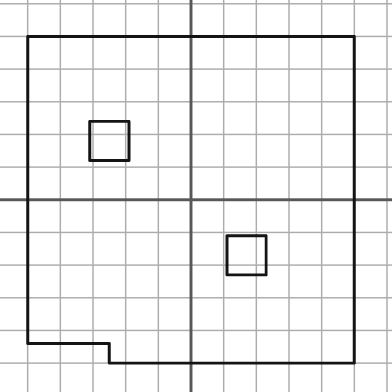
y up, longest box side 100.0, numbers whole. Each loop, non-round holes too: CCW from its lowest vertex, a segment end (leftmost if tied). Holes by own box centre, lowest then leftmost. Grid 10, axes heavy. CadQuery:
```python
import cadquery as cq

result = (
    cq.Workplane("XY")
    .moveTo(-25.0, -50.0)
    .lineTo(50.0, -50.0)
    .lineTo(50.0, 50.0)
    .lineTo(-50.0, 50.0)
    .lineTo(-50.0, -44.0)
    .lineTo(-25.0, -44.0)
    .close()
    .moveTo(11.0, -23.0)
    .lineTo(23.0, -23.0)
    .lineTo(23.0, -11.0)
    .lineTo(11.0, -11.0)
    .close()
    .moveTo(-31.0, 12.0)
    .lineTo(-19.0, 12.0)
    .lineTo(-19.0, 24.0)
    .lineTo(-31.0, 24.0)
    .close()
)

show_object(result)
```